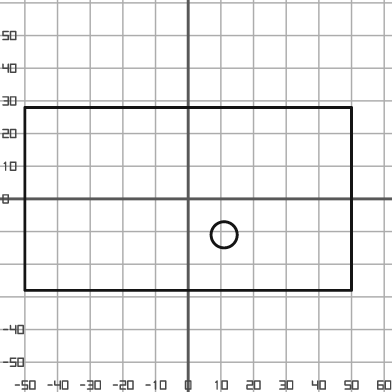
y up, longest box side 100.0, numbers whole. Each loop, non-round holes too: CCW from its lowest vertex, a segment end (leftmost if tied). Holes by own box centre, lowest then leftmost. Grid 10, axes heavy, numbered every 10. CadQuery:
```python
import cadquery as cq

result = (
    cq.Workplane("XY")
    .moveTo(-50.0, -28.0)
    .lineTo(50.0, -28.0)
    .lineTo(50.0, 28.0)
    .lineTo(-50.0, 28.0)
    .close()
    .moveTo(11.0, -11.0)
    .circle(4.0)
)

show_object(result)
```